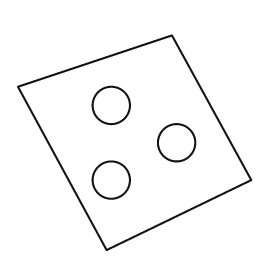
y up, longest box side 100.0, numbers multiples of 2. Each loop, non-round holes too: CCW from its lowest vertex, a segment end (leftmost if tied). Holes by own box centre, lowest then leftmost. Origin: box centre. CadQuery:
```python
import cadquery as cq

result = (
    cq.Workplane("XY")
    .moveTo(-12.0, -46.0)
    .lineTo(50.0, -16.0)
    .lineTo(16.0, 46.0)
    .lineTo(-50.0, 24.0)
    .close()
    .moveTo(-10.0, -16.0)
    .circle(8.0)
    .moveTo(18.0, 0.0)
    .circle(8.0)
    .moveTo(-10.0, 16.0)
    .circle(8.0)
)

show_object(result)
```